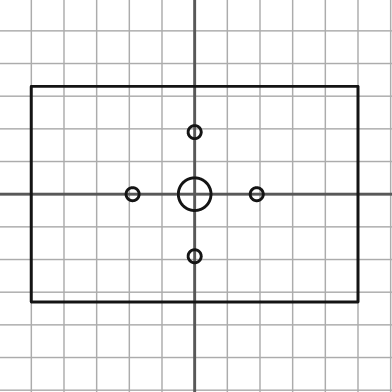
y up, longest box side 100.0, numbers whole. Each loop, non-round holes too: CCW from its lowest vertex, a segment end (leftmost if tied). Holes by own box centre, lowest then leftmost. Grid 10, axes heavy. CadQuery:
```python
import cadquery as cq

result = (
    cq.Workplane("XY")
    .moveTo(-50.0, -33.0)
    .lineTo(50.0, -33.0)
    .lineTo(50.0, 33.0)
    .lineTo(-50.0, 33.0)
    .close()
    .moveTo(0.0, -19.0)
    .circle(2.0)
    .moveTo(-19.0, 0.0)
    .circle(2.0)
    .moveTo(0.0, 0.0)
    .circle(5.0)
    .moveTo(19.0, 0.0)
    .circle(2.0)
    .moveTo(0.0, 19.0)
    .circle(2.0)
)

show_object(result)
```